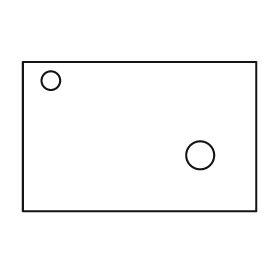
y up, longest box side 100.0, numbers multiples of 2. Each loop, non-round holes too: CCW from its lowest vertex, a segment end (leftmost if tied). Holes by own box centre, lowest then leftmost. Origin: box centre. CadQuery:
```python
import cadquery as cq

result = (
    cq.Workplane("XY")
    .moveTo(-50.0, -32.0)
    .lineTo(50.0, -32.0)
    .lineTo(50.0, 32.0)
    .lineTo(-50.0, 32.0)
    .close()
    .moveTo(26.0, -8.0)
    .circle(6.0)
    .moveTo(-38.0, 24.0)
    .circle(4.0)
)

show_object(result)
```